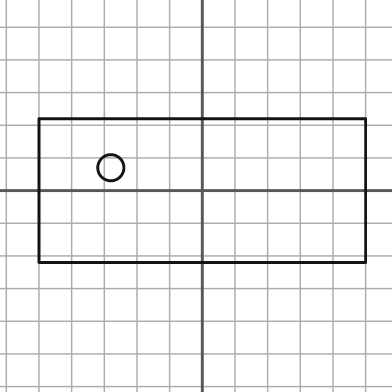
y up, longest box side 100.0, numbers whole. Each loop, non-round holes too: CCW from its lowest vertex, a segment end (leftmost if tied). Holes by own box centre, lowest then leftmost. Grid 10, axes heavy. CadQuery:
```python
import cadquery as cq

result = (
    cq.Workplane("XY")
    .moveTo(-50.0, -22.0)
    .lineTo(50.0, -22.0)
    .lineTo(50.0, 22.0)
    .lineTo(-50.0, 22.0)
    .close()
    .moveTo(-28.0, 7.0)
    .circle(4.0)
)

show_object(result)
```